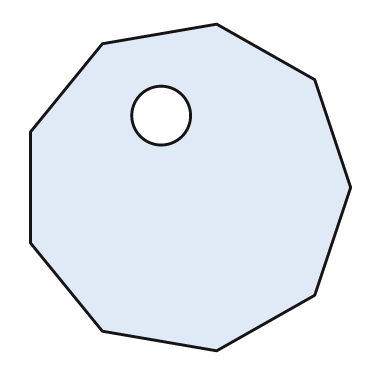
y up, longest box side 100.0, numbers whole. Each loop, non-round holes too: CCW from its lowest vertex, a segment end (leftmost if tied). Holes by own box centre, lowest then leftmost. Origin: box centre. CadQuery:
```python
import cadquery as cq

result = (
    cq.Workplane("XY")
    .moveTo(8.0, -50.0)
    .lineTo(38.0, -33.0)
    .lineTo(49.0, 0.0)
    .lineTo(38.0, 33.0)
    .lineTo(8.0, 50.0)
    .lineTo(-27.0, 44.0)
    .lineTo(-49.0, 17.0)
    .lineTo(-49.0, -17.0)
    .lineTo(-27.0, -44.0)
    .close()
    .moveTo(-9.0, 22.0)
    .circle(9.0)
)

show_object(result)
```